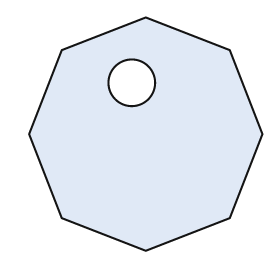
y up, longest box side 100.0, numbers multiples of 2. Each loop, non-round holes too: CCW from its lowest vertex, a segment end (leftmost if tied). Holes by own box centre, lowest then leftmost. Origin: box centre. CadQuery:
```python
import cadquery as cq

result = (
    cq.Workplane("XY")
    .moveTo(0.0, -50.0)
    .lineTo(36.0, -36.0)
    .lineTo(50.0, 0.0)
    .lineTo(36.0, 36.0)
    .lineTo(0.0, 50.0)
    .lineTo(-36.0, 36.0)
    .lineTo(-50.0, 0.0)
    .lineTo(-36.0, -36.0)
    .close()
    .moveTo(-6.0, 22.0)
    .circle(10.0)
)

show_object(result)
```